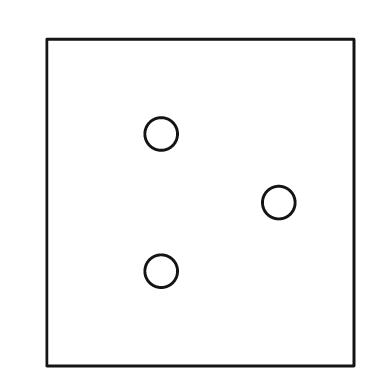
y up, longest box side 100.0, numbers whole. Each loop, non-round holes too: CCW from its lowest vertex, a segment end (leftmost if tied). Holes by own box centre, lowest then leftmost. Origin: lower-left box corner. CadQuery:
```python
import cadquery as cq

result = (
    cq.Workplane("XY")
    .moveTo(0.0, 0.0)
    .lineTo(94.0, 0.0)
    .lineTo(94.0, 100.0)
    .lineTo(0.0, 100.0)
    .close()
    .moveTo(35.0, 29.0)
    .circle(5.0)
    .moveTo(71.0, 50.0)
    .circle(5.0)
    .moveTo(35.0, 71.0)
    .circle(5.0)
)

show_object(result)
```